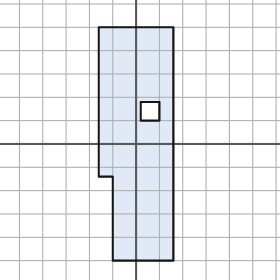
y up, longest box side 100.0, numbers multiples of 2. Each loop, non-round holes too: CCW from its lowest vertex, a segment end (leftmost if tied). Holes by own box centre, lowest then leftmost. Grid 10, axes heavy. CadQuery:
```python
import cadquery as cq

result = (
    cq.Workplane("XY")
    .moveTo(-10.0, -50.0)
    .lineTo(16.0, -50.0)
    .lineTo(16.0, 50.0)
    .lineTo(-16.0, 50.0)
    .lineTo(-16.0, -14.0)
    .lineTo(-10.0, -14.0)
    .close()
    .moveTo(2.0, 10.0)
    .lineTo(10.0, 10.0)
    .lineTo(10.0, 18.0)
    .lineTo(2.0, 18.0)
    .close()
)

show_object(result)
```